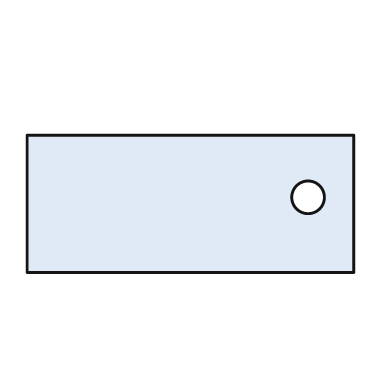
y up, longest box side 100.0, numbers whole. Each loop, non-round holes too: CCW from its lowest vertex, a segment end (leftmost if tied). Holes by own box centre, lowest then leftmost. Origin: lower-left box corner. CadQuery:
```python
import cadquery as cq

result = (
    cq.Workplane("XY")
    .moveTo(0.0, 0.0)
    .lineTo(100.0, 0.0)
    .lineTo(100.0, 42.0)
    .lineTo(0.0, 42.0)
    .close()
    .moveTo(86.0, 23.0)
    .circle(5.0)
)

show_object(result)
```